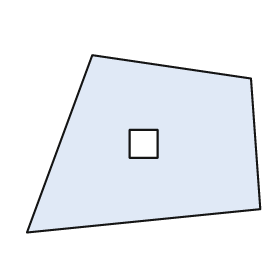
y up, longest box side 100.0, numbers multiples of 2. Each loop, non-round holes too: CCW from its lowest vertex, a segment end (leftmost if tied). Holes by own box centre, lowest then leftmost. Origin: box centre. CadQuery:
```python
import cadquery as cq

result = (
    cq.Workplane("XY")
    .moveTo(-50.0, -38.0)
    .lineTo(50.0, -28.0)
    .lineTo(46.0, 28.0)
    .lineTo(-22.0, 38.0)
    .close()
    .moveTo(-6.0, -6.0)
    .lineTo(6.0, -6.0)
    .lineTo(6.0, 6.0)
    .lineTo(-6.0, 6.0)
    .close()
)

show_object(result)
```